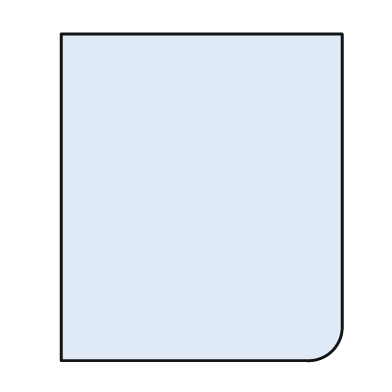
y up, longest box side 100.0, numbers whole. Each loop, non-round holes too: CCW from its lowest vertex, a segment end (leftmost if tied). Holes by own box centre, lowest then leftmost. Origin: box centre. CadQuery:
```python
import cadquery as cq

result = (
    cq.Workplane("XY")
    .moveTo(-43.0, -50.0)
    .lineTo(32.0, -50.0)
    .threePointArc((40.0, -47.0), (43.0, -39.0))
    .lineTo(43.0, 50.0)
    .lineTo(-43.0, 50.0)
    .close()
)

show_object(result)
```